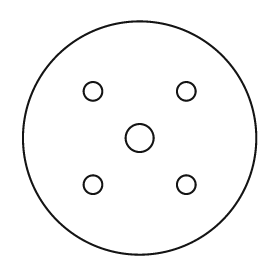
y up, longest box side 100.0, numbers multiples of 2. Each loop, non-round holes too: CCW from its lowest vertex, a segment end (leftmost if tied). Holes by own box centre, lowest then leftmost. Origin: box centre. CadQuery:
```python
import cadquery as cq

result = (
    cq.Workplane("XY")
    .moveTo(0.0, 0.0)
    .circle(50.0)
    .moveTo(-20.0, -20.0)
    .circle(4.0)
    .moveTo(20.0, -20.0)
    .circle(4.0)
    .moveTo(0.0, 0.0)
    .circle(6.0)
    .moveTo(-20.0, 20.0)
    .circle(4.0)
    .moveTo(20.0, 20.0)
    .circle(4.0)
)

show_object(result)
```